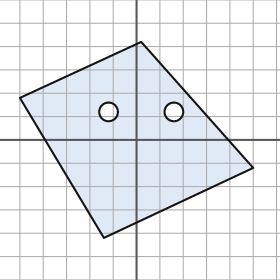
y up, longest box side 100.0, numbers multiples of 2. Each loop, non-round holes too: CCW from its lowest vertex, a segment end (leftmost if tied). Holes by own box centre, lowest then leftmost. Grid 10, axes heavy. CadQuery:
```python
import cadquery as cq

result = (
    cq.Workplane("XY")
    .moveTo(-14.0, -42.0)
    .lineTo(50.0, -12.0)
    .lineTo(2.0, 42.0)
    .lineTo(-50.0, 18.0)
    .close()
    .moveTo(-12.0, 12.0)
    .circle(4.0)
    .moveTo(16.0, 12.0)
    .circle(4.0)
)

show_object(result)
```